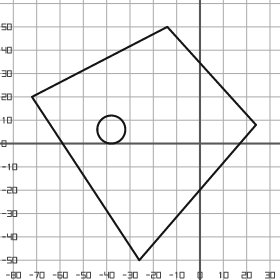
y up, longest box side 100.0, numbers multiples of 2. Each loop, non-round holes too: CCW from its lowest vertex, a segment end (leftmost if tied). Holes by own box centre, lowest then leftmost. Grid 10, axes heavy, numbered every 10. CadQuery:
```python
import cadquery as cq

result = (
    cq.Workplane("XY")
    .moveTo(-26.0, -50.0)
    .lineTo(24.0, 8.0)
    .lineTo(-14.0, 50.0)
    .lineTo(-72.0, 20.0)
    .close()
    .moveTo(-38.0, 6.0)
    .circle(6.0)
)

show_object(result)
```